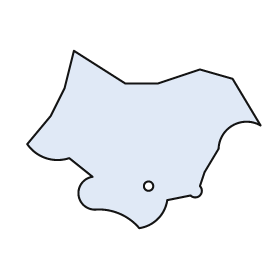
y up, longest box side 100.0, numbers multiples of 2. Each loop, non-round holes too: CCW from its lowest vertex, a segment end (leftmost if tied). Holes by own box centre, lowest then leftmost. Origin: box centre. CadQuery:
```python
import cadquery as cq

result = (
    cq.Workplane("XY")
    .moveTo(-2.0, -38.0)
    .threePointArc((6.0, -34.0), (10.0, -26.0))
    .lineTo(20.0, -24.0)
    .threePointArc((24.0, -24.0), (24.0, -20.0))
    .lineTo(26.0, -14.0)
    .lineTo(32.0, -4.0)
    .threePointArc((38.0, 6.0), (50.0, 6.0))
    .lineTo(38.0, 26.0)
    .lineTo(24.0, 30.0)
    .lineTo(6.0, 24.0)
    .lineTo(-8.0, 24.0)
    .lineTo(-30.0, 38.0)
    .lineTo(-34.0, 22.0)
    .lineTo(-40.0, 10.0)
    .lineTo(-50.0, -2.0)
    .threePointArc((-42.0, -8.0), (-32.0, -8.0))
    .lineTo(-22.0, -16.0)
    .threePointArc((-28.0, -24.0), (-20.0, -30.0))
    .threePointArc((-10.0, -32.0), (-2.0, -38.0))
    .close()
    .moveTo(2.0, -20.0)
    .circle(2.0)
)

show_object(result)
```